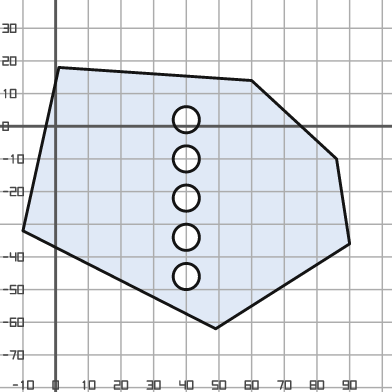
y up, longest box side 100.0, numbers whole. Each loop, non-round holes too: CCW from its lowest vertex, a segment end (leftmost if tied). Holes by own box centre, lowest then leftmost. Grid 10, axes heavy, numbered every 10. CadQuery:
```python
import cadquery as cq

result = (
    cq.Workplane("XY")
    .moveTo(49.0, -62.0)
    .lineTo(90.0, -36.0)
    .lineTo(86.0, -10.0)
    .lineTo(60.0, 14.0)
    .lineTo(1.0, 18.0)
    .lineTo(-10.0, -32.0)
    .close()
    .moveTo(40.0, -46.0)
    .circle(4.0)
    .moveTo(40.0, -34.0)
    .circle(4.0)
    .moveTo(40.0, -22.0)
    .circle(4.0)
    .moveTo(40.0, -10.0)
    .circle(4.0)
    .moveTo(40.0, 2.0)
    .circle(4.0)
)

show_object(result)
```